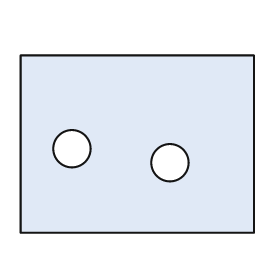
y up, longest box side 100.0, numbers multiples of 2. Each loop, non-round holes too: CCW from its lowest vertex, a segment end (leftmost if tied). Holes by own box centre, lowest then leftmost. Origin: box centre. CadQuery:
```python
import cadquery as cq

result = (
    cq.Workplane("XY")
    .moveTo(-50.0, -38.0)
    .lineTo(50.0, -38.0)
    .lineTo(50.0, 38.0)
    .lineTo(-50.0, 38.0)
    .close()
    .moveTo(14.0, -8.0)
    .circle(8.0)
    .moveTo(-28.0, -2.0)
    .circle(8.0)
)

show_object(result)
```